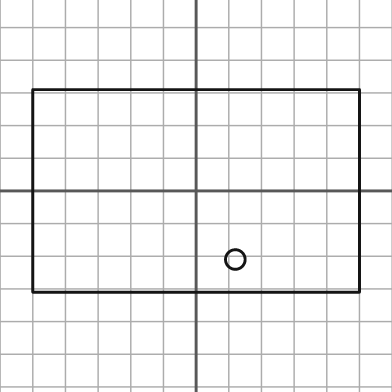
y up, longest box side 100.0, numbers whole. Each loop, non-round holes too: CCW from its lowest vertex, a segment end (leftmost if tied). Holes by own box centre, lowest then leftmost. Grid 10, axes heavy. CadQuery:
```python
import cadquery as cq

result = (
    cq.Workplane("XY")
    .moveTo(-50.0, -31.0)
    .lineTo(50.0, -31.0)
    .lineTo(50.0, 31.0)
    .lineTo(-50.0, 31.0)
    .close()
    .moveTo(12.0, -21.0)
    .circle(3.0)
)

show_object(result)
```